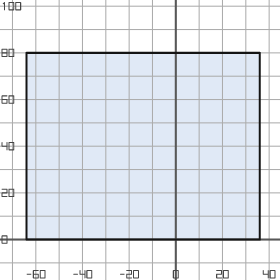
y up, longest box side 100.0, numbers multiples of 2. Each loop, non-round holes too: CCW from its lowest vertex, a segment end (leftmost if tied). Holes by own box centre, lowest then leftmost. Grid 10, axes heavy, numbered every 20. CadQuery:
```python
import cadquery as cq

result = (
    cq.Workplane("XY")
    .moveTo(-64.0, 0.0)
    .lineTo(36.0, 0.0)
    .lineTo(36.0, 80.0)
    .lineTo(-64.0, 80.0)
    .close()
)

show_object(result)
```